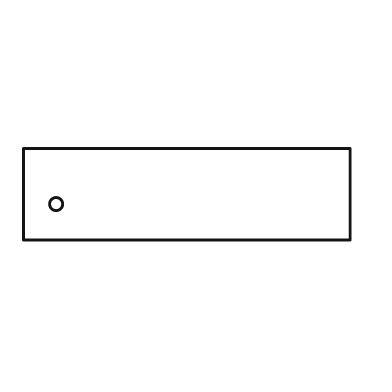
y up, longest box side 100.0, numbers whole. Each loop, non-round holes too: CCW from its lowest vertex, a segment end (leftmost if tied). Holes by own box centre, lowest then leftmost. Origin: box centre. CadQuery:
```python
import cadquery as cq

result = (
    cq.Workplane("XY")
    .moveTo(-50.0, -14.0)
    .lineTo(50.0, -14.0)
    .lineTo(50.0, 14.0)
    .lineTo(-50.0, 14.0)
    .close()
    .moveTo(-40.0, -3.0)
    .circle(2.0)
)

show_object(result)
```